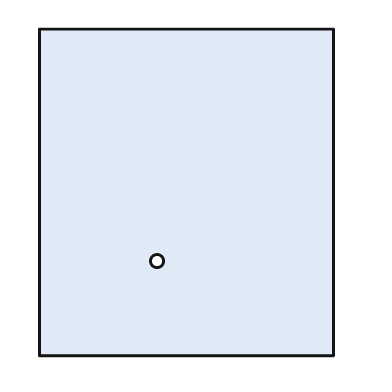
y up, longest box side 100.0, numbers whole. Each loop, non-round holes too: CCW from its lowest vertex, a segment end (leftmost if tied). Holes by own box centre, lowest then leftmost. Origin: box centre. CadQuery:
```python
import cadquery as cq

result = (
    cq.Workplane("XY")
    .moveTo(-45.0, -50.0)
    .lineTo(45.0, -50.0)
    .lineTo(45.0, 50.0)
    .lineTo(-45.0, 50.0)
    .close()
    .moveTo(-9.0, -21.0)
    .circle(2.0)
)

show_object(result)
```